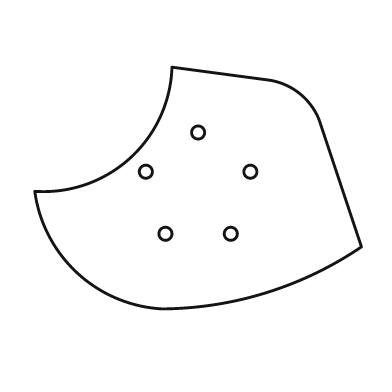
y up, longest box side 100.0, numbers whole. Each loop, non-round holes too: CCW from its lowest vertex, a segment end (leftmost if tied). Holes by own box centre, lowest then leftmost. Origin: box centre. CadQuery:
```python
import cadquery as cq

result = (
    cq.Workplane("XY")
    .moveTo(-11.0, -37.0)
    .threePointArc((21.0, -32.0), (50.0, -18.0))
    .lineTo(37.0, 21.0)
    .threePointArc((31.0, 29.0), (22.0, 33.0))
    .lineTo(-8.0, 37.0)
    .threePointArc((-21.0, 9.0), (-50.0, -1.0))
    .threePointArc((-37.0, -26.0), (-11.0, -37.0))
    .close()
    .moveTo(-10.0, -14.0)
    .circle(2.0)
    .moveTo(10.0, -14.0)
    .circle(2.0)
    .moveTo(-16.0, 5.0)
    .circle(2.0)
    .moveTo(16.0, 5.0)
    .circle(2.0)
    .moveTo(0.0, 17.0)
    .circle(2.0)
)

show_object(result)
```